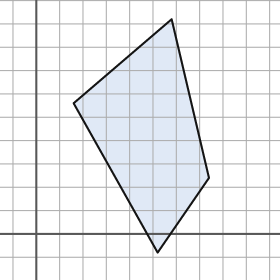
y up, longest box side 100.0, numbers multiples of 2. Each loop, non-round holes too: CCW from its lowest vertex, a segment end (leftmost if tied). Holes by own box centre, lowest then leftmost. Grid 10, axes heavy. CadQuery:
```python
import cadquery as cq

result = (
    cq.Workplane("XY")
    .moveTo(52.0, -8.0)
    .lineTo(74.0, 24.0)
    .lineTo(58.0, 92.0)
    .lineTo(16.0, 56.0)
    .close()
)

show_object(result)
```